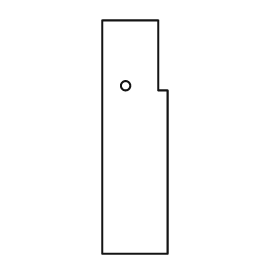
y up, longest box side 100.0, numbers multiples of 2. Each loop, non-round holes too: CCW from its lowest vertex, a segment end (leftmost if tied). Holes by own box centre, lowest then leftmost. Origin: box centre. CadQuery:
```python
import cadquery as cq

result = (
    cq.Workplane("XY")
    .moveTo(-14.0, -50.0)
    .lineTo(14.0, -50.0)
    .lineTo(14.0, 20.0)
    .lineTo(10.0, 20.0)
    .lineTo(10.0, 50.0)
    .lineTo(-14.0, 50.0)
    .close()
    .moveTo(-4.0, 22.0)
    .circle(2.0)
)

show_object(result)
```